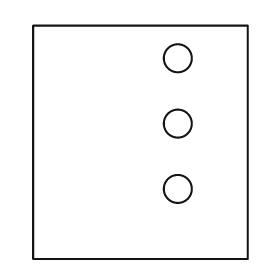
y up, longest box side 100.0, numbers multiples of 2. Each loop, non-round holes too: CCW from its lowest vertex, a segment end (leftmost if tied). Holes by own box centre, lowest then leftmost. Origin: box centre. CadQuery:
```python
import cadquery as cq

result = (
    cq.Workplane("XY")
    .moveTo(-46.0, -50.0)
    .lineTo(46.0, -50.0)
    .lineTo(46.0, 50.0)
    .lineTo(-46.0, 50.0)
    .close()
    .moveTo(16.0, -20.0)
    .circle(6.0)
    .moveTo(16.0, 8.0)
    .circle(6.0)
    .moveTo(16.0, 36.0)
    .circle(6.0)
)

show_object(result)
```